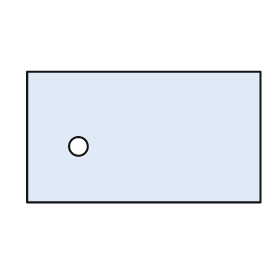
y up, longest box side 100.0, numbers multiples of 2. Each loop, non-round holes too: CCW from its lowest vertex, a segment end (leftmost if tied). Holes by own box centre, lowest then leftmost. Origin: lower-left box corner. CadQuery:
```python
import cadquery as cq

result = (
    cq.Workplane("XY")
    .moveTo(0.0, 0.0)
    .lineTo(100.0, 0.0)
    .lineTo(100.0, 56.0)
    .lineTo(0.0, 56.0)
    .close()
    .moveTo(22.0, 24.0)
    .circle(4.0)
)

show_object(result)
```